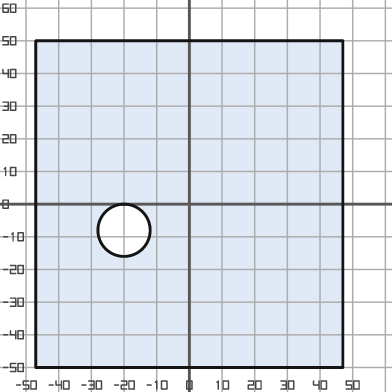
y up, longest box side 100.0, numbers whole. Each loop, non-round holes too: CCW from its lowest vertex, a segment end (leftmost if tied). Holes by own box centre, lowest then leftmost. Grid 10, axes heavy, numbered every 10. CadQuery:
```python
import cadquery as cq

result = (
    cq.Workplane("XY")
    .moveTo(-47.0, -50.0)
    .lineTo(47.0, -50.0)
    .lineTo(47.0, 50.0)
    .lineTo(-47.0, 50.0)
    .close()
    .moveTo(-20.0, -8.0)
    .circle(8.0)
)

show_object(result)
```